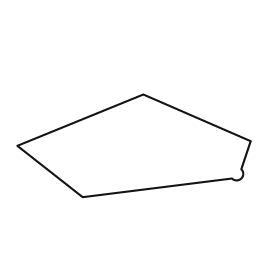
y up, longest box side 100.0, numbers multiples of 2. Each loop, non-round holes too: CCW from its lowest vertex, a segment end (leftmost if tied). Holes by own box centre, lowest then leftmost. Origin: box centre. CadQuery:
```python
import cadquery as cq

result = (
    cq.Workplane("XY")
    .moveTo(-22.0, -22.0)
    .lineTo(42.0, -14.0)
    .threePointArc((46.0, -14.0), (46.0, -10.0))
    .lineTo(50.0, 2.0)
    .lineTo(4.0, 22.0)
    .lineTo(-50.0, 0.0)
    .close()
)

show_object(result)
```